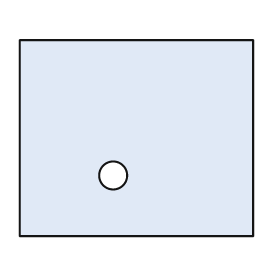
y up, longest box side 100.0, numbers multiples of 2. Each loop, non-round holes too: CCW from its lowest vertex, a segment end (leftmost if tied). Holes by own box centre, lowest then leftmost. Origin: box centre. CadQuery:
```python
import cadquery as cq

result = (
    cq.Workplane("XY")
    .moveTo(-50.0, -42.0)
    .lineTo(50.0, -42.0)
    .lineTo(50.0, 42.0)
    .lineTo(-50.0, 42.0)
    .close()
    .moveTo(-10.0, -16.0)
    .circle(6.0)
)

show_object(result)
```